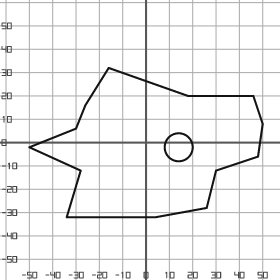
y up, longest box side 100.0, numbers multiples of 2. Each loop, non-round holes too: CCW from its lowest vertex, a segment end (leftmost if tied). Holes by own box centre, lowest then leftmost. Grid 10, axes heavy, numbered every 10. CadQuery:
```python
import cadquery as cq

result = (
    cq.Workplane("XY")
    .moveTo(-34.0, -32.0)
    .lineTo(4.0, -32.0)
    .lineTo(26.0, -28.0)
    .lineTo(30.0, -12.0)
    .lineTo(48.0, -6.0)
    .lineTo(50.0, 8.0)
    .lineTo(46.0, 20.0)
    .lineTo(18.0, 20.0)
    .lineTo(-16.0, 32.0)
    .lineTo(-26.0, 16.0)
    .lineTo(-30.0, 6.0)
    .lineTo(-50.0, -2.0)
    .lineTo(-28.0, -12.0)
    .close()
    .moveTo(14.0, -2.0)
    .circle(6.0)
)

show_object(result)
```